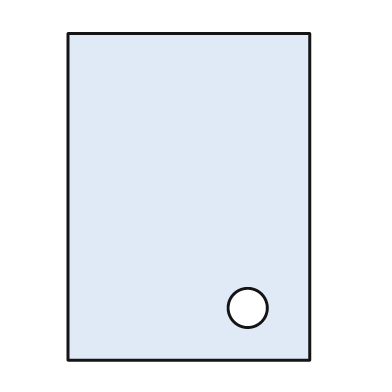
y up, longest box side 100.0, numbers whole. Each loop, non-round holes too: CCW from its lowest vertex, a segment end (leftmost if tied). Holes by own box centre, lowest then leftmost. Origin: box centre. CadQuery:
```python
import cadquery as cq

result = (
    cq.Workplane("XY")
    .moveTo(-37.0, -50.0)
    .lineTo(37.0, -50.0)
    .lineTo(37.0, 50.0)
    .lineTo(-37.0, 50.0)
    .close()
    .moveTo(18.0, -34.0)
    .circle(6.0)
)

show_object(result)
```